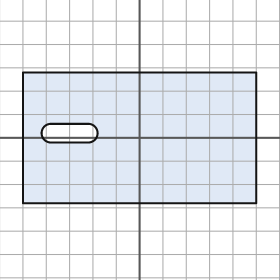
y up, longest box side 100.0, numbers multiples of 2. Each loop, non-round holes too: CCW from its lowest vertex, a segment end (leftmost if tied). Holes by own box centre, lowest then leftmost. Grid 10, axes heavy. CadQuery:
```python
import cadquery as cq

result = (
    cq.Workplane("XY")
    .moveTo(-50.0, -28.0)
    .lineTo(50.0, -28.0)
    .lineTo(50.0, 28.0)
    .lineTo(-50.0, 28.0)
    .close()
    .moveTo(-38.0, -2.0)
    .lineTo(-22.0, -2.0)
    .threePointArc((-18.0, 2.0), (-22.0, 6.0))
    .lineTo(-38.0, 6.0)
    .threePointArc((-42.0, 2.0), (-38.0, -2.0))
    .close()
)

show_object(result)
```